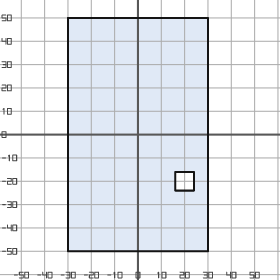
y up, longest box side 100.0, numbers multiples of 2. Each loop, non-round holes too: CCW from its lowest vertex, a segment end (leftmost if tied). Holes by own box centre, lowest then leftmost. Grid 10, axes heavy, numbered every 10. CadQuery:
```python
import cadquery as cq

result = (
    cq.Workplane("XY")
    .moveTo(-30.0, -50.0)
    .lineTo(30.0, -50.0)
    .lineTo(30.0, 50.0)
    .lineTo(-30.0, 50.0)
    .close()
    .moveTo(16.0, -24.0)
    .lineTo(24.0, -24.0)
    .lineTo(24.0, -16.0)
    .lineTo(16.0, -16.0)
    .close()
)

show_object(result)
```